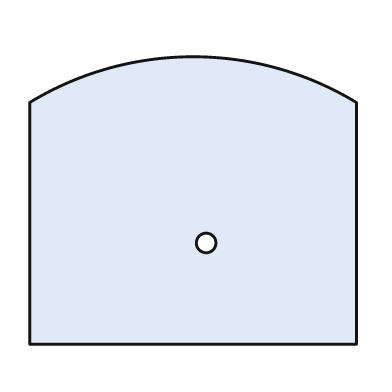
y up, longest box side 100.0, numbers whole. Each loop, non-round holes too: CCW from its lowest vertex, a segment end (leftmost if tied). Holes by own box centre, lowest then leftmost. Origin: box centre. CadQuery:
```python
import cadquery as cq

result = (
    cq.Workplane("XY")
    .moveTo(-50.0, -44.0)
    .lineTo(50.0, -44.0)
    .lineTo(50.0, 30.0)
    .threePointArc((0.0, 44.0), (-50.0, 30.0))
    .close()
    .moveTo(4.0, -13.0)
    .circle(3.0)
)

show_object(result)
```